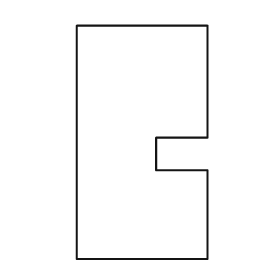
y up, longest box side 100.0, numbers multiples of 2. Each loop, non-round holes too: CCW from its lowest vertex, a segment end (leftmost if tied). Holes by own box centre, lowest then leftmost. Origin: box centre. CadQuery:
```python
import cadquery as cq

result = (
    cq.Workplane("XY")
    .moveTo(-28.0, -50.0)
    .lineTo(28.0, -50.0)
    .lineTo(28.0, -12.0)
    .lineTo(6.0, -12.0)
    .lineTo(6.0, 2.0)
    .lineTo(28.0, 2.0)
    .lineTo(28.0, 50.0)
    .lineTo(-28.0, 50.0)
    .close()
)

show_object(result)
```